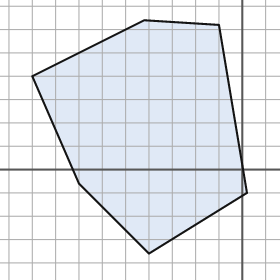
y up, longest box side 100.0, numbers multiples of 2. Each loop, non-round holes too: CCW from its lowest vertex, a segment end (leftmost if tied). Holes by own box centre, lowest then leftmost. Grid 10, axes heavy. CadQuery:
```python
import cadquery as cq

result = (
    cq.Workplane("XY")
    .moveTo(-40.0, -36.0)
    .lineTo(2.0, -10.0)
    .lineTo(-10.0, 62.0)
    .lineTo(-42.0, 64.0)
    .lineTo(-90.0, 40.0)
    .lineTo(-70.0, -6.0)
    .close()
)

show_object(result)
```